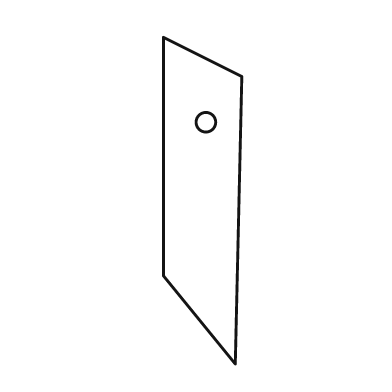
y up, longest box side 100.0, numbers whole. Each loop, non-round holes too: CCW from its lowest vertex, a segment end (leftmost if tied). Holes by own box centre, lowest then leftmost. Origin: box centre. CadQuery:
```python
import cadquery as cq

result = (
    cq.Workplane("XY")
    .moveTo(10.0, -50.0)
    .lineTo(12.0, 38.0)
    .lineTo(-12.0, 50.0)
    .lineTo(-12.0, -23.0)
    .close()
    .moveTo(1.0, 24.0)
    .circle(3.0)
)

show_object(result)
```